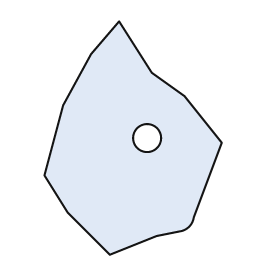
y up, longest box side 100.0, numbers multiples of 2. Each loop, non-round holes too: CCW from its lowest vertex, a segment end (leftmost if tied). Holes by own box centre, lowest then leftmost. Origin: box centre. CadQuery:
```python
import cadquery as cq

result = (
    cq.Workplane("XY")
    .moveTo(-10.0, -50.0)
    .lineTo(10.0, -42.0)
    .lineTo(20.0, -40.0)
    .threePointArc((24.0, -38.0), (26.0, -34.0))
    .lineTo(38.0, -2.0)
    .lineTo(22.0, 18.0)
    .lineTo(8.0, 28.0)
    .lineTo(-6.0, 50.0)
    .lineTo(-18.0, 36.0)
    .lineTo(-30.0, 14.0)
    .lineTo(-38.0, -16.0)
    .lineTo(-28.0, -32.0)
    .close()
    .moveTo(6.0, 0.0)
    .circle(6.0)
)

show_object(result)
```